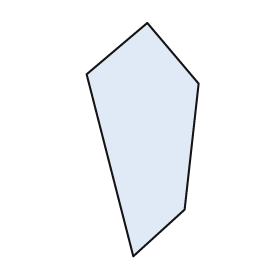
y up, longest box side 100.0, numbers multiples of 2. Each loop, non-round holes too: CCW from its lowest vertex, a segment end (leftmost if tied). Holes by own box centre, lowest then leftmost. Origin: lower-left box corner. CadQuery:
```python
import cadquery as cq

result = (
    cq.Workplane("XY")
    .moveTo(20.0, 0.0)
    .lineTo(42.0, 20.0)
    .lineTo(48.0, 74.0)
    .lineTo(26.0, 100.0)
    .lineTo(0.0, 78.0)
    .close()
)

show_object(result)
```